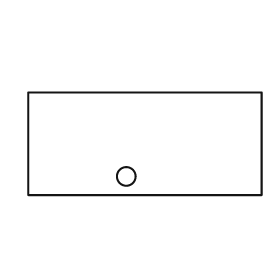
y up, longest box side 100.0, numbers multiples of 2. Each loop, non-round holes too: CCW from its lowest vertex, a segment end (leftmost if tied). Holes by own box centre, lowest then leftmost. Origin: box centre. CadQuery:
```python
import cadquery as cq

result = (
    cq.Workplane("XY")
    .moveTo(-50.0, -22.0)
    .lineTo(50.0, -22.0)
    .lineTo(50.0, 22.0)
    .lineTo(-50.0, 22.0)
    .close()
    .moveTo(-8.0, -14.0)
    .circle(4.0)
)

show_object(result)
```